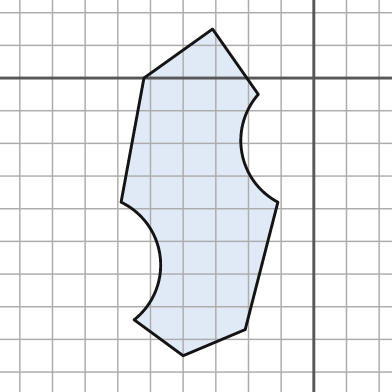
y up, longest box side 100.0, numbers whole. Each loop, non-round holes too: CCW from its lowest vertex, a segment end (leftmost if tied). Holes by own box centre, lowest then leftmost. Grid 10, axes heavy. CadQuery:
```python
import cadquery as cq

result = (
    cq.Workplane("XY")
    .moveTo(-40.0, -85.0)
    .lineTo(-21.0, -77.0)
    .lineTo(-11.0, -38.0)
    .threePointArc((-22.0, -23.0), (-17.0, -5.0))
    .lineTo(-31.0, 15.0)
    .lineTo(-52.0, 0.0)
    .lineTo(-59.0, -38.0)
    .threePointArc((-47.0, -55.0), (-55.0, -74.0))
    .close()
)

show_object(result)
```